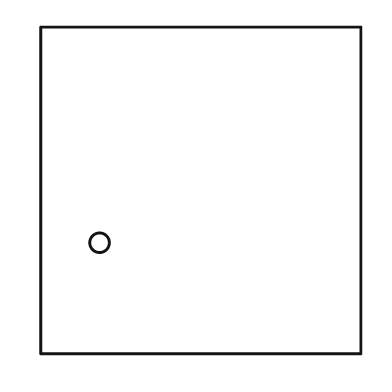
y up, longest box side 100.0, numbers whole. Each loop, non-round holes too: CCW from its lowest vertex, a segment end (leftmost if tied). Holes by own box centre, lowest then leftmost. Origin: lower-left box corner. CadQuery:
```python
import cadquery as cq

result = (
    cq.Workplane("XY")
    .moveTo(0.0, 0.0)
    .lineTo(98.0, 0.0)
    .lineTo(98.0, 100.0)
    .lineTo(0.0, 100.0)
    .close()
    .moveTo(18.0, 34.0)
    .circle(3.0)
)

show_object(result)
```